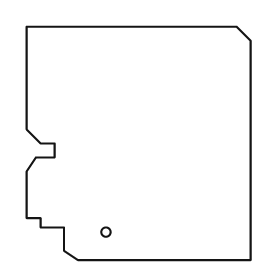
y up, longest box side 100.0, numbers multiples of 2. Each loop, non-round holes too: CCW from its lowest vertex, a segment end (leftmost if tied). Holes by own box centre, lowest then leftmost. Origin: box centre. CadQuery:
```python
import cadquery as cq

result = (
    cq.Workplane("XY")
    .moveTo(-26.0, -50.0)
    .lineTo(48.0, -50.0)
    .lineTo(48.0, 44.0)
    .lineTo(42.0, 50.0)
    .lineTo(-48.0, 50.0)
    .lineTo(-48.0, 6.0)
    .lineTo(-42.0, 0.0)
    .lineTo(-36.0, 0.0)
    .lineTo(-36.0, -6.0)
    .lineTo(-44.0, -6.0)
    .lineTo(-48.0, -12.0)
    .lineTo(-48.0, -32.0)
    .lineTo(-42.0, -32.0)
    .lineTo(-42.0, -36.0)
    .lineTo(-32.0, -36.0)
    .lineTo(-32.0, -46.0)
    .close()
    .moveTo(-14.0, -38.0)
    .circle(2.0)
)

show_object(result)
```